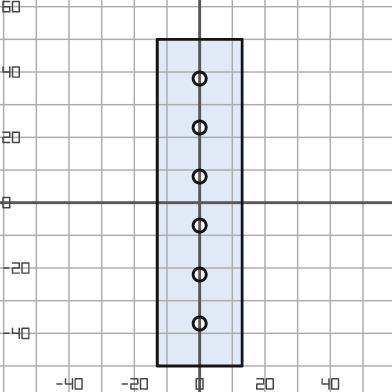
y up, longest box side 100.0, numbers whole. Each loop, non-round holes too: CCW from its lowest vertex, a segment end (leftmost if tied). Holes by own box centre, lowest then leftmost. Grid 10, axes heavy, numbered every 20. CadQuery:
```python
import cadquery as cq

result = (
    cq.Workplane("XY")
    .moveTo(-13.0, -50.0)
    .lineTo(13.0, -50.0)
    .lineTo(13.0, 50.0)
    .lineTo(-13.0, 50.0)
    .close()
    .moveTo(0.0, -37.0)
    .circle(2.0)
    .moveTo(0.0, -22.0)
    .circle(2.0)
    .moveTo(0.0, -7.0)
    .circle(2.0)
    .moveTo(0.0, 8.0)
    .circle(2.0)
    .moveTo(0.0, 23.0)
    .circle(2.0)
    .moveTo(0.0, 38.0)
    .circle(2.0)
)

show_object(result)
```